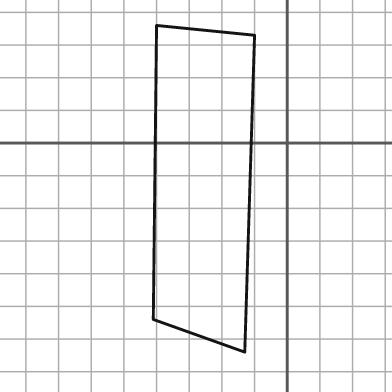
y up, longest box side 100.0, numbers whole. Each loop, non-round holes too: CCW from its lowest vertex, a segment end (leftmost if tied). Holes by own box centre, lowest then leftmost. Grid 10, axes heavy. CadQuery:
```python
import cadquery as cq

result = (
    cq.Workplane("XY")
    .moveTo(-13.0, -64.0)
    .lineTo(-10.0, 33.0)
    .lineTo(-40.0, 36.0)
    .lineTo(-41.0, -54.0)
    .close()
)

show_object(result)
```